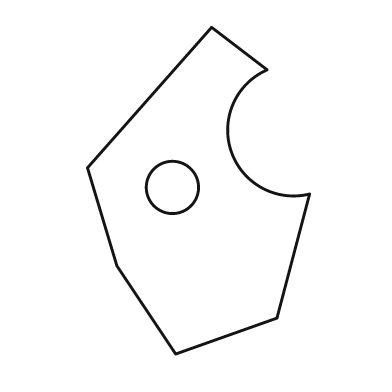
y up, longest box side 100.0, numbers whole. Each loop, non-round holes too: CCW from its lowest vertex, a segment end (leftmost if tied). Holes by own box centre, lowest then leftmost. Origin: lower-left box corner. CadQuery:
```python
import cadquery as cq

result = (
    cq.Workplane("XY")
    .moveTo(27.0, 0.0)
    .lineTo(58.0, 11.0)
    .lineTo(68.0, 49.0)
    .threePointArc((44.0, 62.0), (55.0, 87.0))
    .lineTo(38.0, 100.0)
    .lineTo(0.0, 57.0)
    .lineTo(9.0, 27.0)
    .close()
    .moveTo(26.0, 51.0)
    .circle(8.0)
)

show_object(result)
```